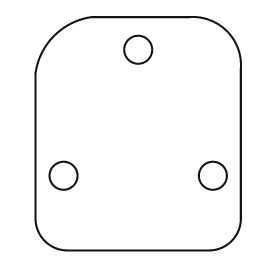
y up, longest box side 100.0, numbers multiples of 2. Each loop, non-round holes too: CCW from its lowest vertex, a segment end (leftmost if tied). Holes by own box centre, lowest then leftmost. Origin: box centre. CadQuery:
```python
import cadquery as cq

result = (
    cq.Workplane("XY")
    .moveTo(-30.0, -50.0)
    .lineTo(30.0, -50.0)
    .threePointArc((40.0, -46.0), (44.0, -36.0))
    .lineTo(44.0, 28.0)
    .threePointArc((38.0, 44.0), (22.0, 50.0))
    .lineTo(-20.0, 50.0)
    .threePointArc((-36.0, 42.0), (-44.0, 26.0))
    .lineTo(-44.0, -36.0)
    .threePointArc((-40.0, -46.0), (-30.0, -50.0))
    .close()
    .moveTo(-32.0, -18.0)
    .circle(6.0)
    .moveTo(32.0, -18.0)
    .circle(6.0)
    .moveTo(0.0, 36.0)
    .circle(6.0)
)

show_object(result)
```